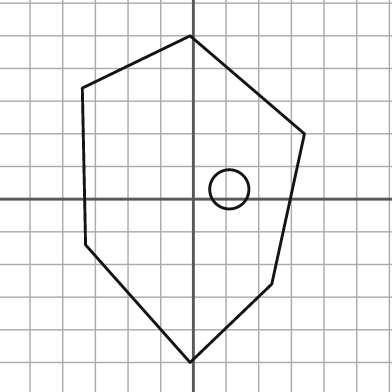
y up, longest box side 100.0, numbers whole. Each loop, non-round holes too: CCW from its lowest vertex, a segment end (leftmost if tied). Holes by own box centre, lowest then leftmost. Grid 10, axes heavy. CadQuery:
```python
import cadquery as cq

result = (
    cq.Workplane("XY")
    .moveTo(-1.0, -50.0)
    .lineTo(24.0, -26.0)
    .lineTo(34.0, 20.0)
    .lineTo(-1.0, 50.0)
    .lineTo(-34.0, 34.0)
    .lineTo(-33.0, -14.0)
    .close()
    .moveTo(11.0, 3.0)
    .circle(6.0)
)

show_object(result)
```